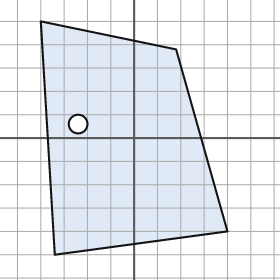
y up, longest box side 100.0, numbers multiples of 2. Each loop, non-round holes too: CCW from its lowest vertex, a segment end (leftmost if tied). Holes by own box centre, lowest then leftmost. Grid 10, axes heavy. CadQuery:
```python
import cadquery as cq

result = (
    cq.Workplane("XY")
    .moveTo(-34.0, -50.0)
    .lineTo(40.0, -40.0)
    .lineTo(18.0, 38.0)
    .lineTo(-40.0, 50.0)
    .close()
    .moveTo(-24.0, 6.0)
    .circle(4.0)
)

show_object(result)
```